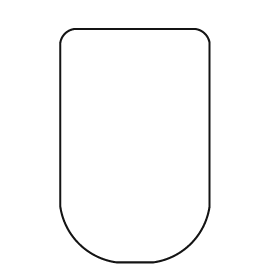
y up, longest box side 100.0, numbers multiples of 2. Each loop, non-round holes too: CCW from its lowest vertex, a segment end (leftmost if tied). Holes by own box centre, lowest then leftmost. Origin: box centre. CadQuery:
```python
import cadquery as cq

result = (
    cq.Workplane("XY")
    .moveTo(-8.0, -50.0)
    .lineTo(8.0, -50.0)
    .threePointArc((24.0, -42.0), (32.0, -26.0))
    .lineTo(32.0, 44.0)
    .threePointArc((30.0, 48.0), (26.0, 50.0))
    .lineTo(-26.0, 50.0)
    .threePointArc((-30.0, 48.0), (-32.0, 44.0))
    .lineTo(-32.0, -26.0)
    .threePointArc((-24.0, -42.0), (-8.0, -50.0))
    .close()
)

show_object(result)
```